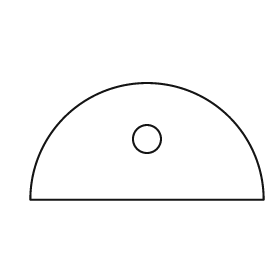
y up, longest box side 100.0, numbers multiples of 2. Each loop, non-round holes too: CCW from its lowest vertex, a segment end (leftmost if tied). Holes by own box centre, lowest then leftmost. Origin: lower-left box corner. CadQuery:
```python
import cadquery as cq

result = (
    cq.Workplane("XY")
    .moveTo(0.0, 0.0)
    .lineTo(100.0, 0.0)
    .threePointArc((50.0, 50.0), (0.0, 0.0))
    .close()
    .moveTo(50.0, 26.0)
    .circle(6.0)
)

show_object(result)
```